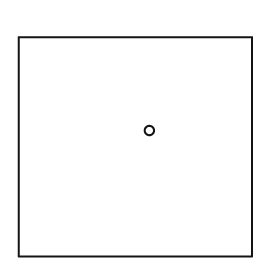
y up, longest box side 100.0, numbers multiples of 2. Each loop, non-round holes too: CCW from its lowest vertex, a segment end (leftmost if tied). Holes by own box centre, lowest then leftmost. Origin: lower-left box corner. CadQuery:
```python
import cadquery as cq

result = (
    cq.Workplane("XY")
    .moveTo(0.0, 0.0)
    .lineTo(100.0, 0.0)
    .lineTo(100.0, 94.0)
    .lineTo(0.0, 94.0)
    .close()
    .moveTo(56.0, 54.0)
    .circle(2.0)
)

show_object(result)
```